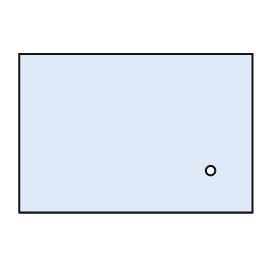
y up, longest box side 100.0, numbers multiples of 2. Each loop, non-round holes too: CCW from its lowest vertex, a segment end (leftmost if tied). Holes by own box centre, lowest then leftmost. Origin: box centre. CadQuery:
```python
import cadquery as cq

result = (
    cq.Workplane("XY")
    .moveTo(-50.0, -34.0)
    .lineTo(50.0, -34.0)
    .lineTo(50.0, 34.0)
    .lineTo(-50.0, 34.0)
    .close()
    .moveTo(32.0, -16.0)
    .circle(2.0)
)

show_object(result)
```